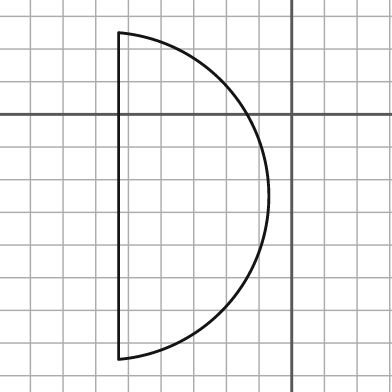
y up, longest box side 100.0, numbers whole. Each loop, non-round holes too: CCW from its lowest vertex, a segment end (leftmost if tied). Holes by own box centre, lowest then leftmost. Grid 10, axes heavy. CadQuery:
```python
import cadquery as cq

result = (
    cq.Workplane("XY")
    .moveTo(-53.0, -75.0)
    .threePointArc((-7.0, -25.0), (-53.0, 25.0))
    .close()
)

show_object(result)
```